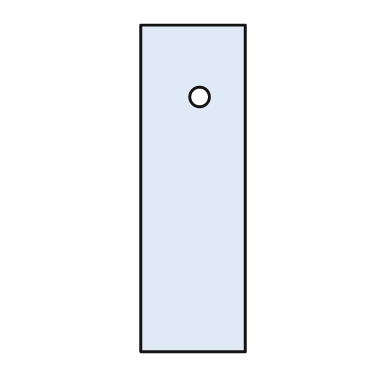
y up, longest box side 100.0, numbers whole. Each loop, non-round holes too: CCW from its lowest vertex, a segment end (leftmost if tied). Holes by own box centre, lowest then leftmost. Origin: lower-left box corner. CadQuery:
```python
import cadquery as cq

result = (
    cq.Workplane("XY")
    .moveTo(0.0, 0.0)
    .lineTo(32.0, 0.0)
    .lineTo(32.0, 100.0)
    .lineTo(0.0, 100.0)
    .close()
    .moveTo(18.0, 78.0)
    .circle(3.0)
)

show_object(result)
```